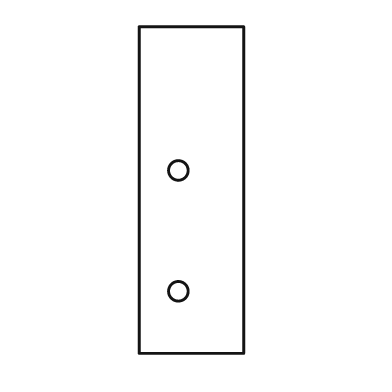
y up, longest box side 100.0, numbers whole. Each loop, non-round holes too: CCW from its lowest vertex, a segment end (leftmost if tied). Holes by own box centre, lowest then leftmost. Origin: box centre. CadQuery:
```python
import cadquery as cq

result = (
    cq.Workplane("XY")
    .moveTo(-16.0, -50.0)
    .lineTo(16.0, -50.0)
    .lineTo(16.0, 50.0)
    .lineTo(-16.0, 50.0)
    .close()
    .moveTo(-4.0, -31.0)
    .circle(3.0)
    .moveTo(-4.0, 6.0)
    .circle(3.0)
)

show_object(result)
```